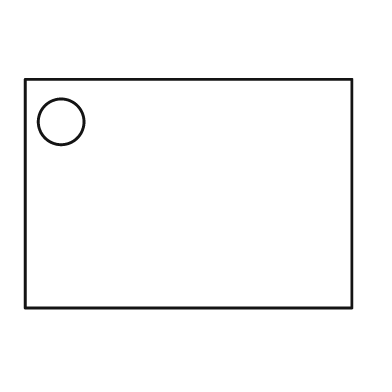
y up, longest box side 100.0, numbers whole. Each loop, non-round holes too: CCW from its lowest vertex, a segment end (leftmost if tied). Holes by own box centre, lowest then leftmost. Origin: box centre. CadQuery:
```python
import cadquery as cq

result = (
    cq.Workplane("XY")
    .moveTo(-50.0, -35.0)
    .lineTo(50.0, -35.0)
    .lineTo(50.0, 35.0)
    .lineTo(-50.0, 35.0)
    .close()
    .moveTo(-39.0, 22.0)
    .circle(7.0)
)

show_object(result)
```